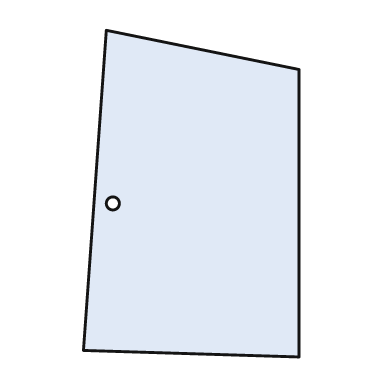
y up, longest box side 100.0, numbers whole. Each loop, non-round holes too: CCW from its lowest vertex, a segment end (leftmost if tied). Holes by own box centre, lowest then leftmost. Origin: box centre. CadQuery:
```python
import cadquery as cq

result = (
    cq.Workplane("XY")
    .moveTo(33.0, -50.0)
    .lineTo(33.0, 38.0)
    .lineTo(-26.0, 50.0)
    .lineTo(-33.0, -48.0)
    .close()
    .moveTo(-24.0, -3.0)
    .circle(2.0)
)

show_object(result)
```